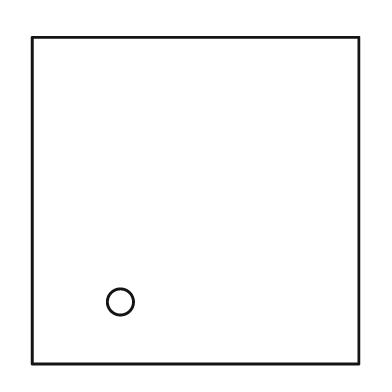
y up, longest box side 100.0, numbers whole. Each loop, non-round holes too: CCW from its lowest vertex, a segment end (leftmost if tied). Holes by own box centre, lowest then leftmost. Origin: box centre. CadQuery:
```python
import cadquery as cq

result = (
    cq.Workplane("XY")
    .moveTo(-50.0, -50.0)
    .lineTo(50.0, -50.0)
    .lineTo(50.0, 50.0)
    .lineTo(-50.0, 50.0)
    .close()
    .moveTo(-23.0, -31.0)
    .circle(4.0)
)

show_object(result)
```